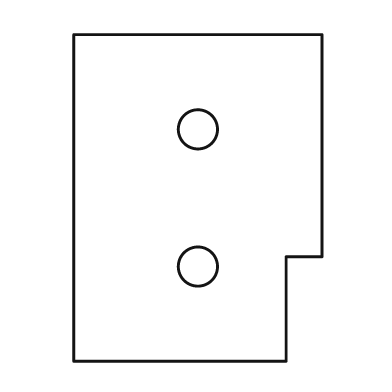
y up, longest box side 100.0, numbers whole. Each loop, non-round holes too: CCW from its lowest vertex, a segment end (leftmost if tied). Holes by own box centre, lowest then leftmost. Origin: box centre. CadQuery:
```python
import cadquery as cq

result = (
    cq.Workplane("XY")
    .moveTo(-38.0, -50.0)
    .lineTo(27.0, -50.0)
    .lineTo(27.0, -18.0)
    .lineTo(38.0, -18.0)
    .lineTo(38.0, 50.0)
    .lineTo(-38.0, 50.0)
    .close()
    .moveTo(0.0, -21.0)
    .circle(6.0)
    .moveTo(0.0, 21.0)
    .circle(6.0)
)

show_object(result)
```